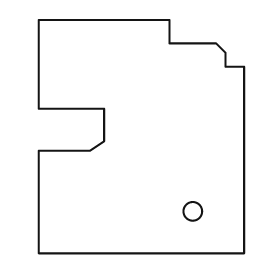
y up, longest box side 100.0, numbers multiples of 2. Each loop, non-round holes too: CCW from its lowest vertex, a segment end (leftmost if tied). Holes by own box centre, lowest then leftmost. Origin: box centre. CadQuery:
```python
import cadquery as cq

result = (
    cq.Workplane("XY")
    .moveTo(-44.0, -50.0)
    .lineTo(44.0, -50.0)
    .lineTo(44.0, 30.0)
    .lineTo(36.0, 30.0)
    .lineTo(36.0, 36.0)
    .lineTo(32.0, 40.0)
    .lineTo(12.0, 40.0)
    .lineTo(12.0, 50.0)
    .lineTo(-44.0, 50.0)
    .lineTo(-44.0, 12.0)
    .lineTo(-16.0, 12.0)
    .lineTo(-16.0, -2.0)
    .lineTo(-22.0, -6.0)
    .lineTo(-44.0, -6.0)
    .close()
    .moveTo(22.0, -32.0)
    .circle(4.0)
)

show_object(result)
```